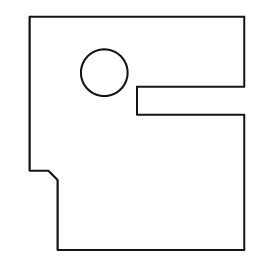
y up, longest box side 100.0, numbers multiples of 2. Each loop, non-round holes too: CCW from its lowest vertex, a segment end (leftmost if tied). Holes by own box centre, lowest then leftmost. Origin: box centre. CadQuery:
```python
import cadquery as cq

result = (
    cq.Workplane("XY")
    .moveTo(-34.0, -50.0)
    .lineTo(46.0, -50.0)
    .lineTo(46.0, 8.0)
    .lineTo(0.0, 8.0)
    .lineTo(0.0, 20.0)
    .lineTo(46.0, 20.0)
    .lineTo(46.0, 50.0)
    .lineTo(-46.0, 50.0)
    .lineTo(-46.0, -16.0)
    .lineTo(-38.0, -16.0)
    .lineTo(-34.0, -20.0)
    .close()
    .moveTo(-14.0, 26.0)
    .circle(10.0)
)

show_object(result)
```